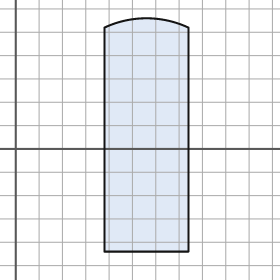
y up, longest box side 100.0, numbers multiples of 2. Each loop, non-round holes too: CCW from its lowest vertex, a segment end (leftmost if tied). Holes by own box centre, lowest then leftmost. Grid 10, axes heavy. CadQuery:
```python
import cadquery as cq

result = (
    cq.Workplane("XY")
    .moveTo(38.0, -44.0)
    .lineTo(74.0, -44.0)
    .lineTo(74.0, 52.0)
    .threePointArc((56.0, 56.0), (38.0, 52.0))
    .close()
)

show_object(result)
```